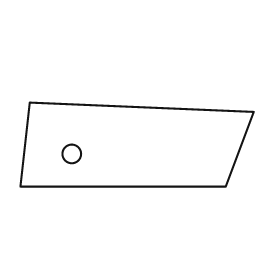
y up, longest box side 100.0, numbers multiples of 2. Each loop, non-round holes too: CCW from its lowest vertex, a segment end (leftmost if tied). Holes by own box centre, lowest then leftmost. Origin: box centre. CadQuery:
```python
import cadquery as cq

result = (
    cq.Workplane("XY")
    .moveTo(-50.0, -18.0)
    .lineTo(38.0, -18.0)
    .lineTo(50.0, 14.0)
    .lineTo(-46.0, 18.0)
    .close()
    .moveTo(-28.0, -4.0)
    .circle(4.0)
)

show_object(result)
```